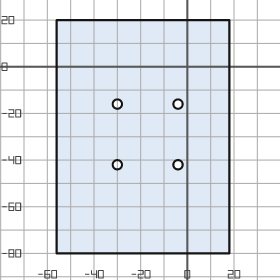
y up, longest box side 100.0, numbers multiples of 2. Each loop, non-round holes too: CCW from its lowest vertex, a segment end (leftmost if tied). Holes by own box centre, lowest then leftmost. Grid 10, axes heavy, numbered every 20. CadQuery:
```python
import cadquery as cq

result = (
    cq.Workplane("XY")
    .moveTo(-56.0, -80.0)
    .lineTo(18.0, -80.0)
    .lineTo(18.0, 20.0)
    .lineTo(-56.0, 20.0)
    .close()
    .moveTo(-30.0, -42.0)
    .circle(2.0)
    .moveTo(-4.0, -42.0)
    .circle(2.0)
    .moveTo(-30.0, -16.0)
    .circle(2.0)
    .moveTo(-4.0, -16.0)
    .circle(2.0)
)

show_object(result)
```